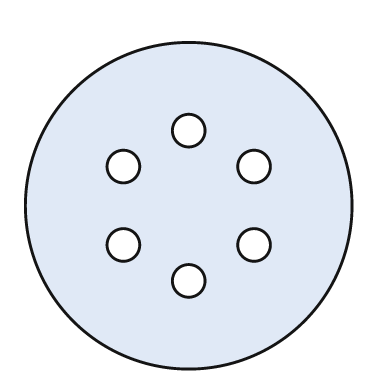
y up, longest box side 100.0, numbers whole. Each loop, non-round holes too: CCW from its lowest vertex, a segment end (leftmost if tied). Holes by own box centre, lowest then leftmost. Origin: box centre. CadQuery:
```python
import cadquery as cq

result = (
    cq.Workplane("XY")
    .moveTo(0.0, 0.0)
    .circle(50.0)
    .moveTo(0.0, -23.0)
    .circle(5.0)
    .moveTo(-20.0, -12.0)
    .circle(5.0)
    .moveTo(20.0, -12.0)
    .circle(5.0)
    .moveTo(-20.0, 12.0)
    .circle(5.0)
    .moveTo(20.0, 12.0)
    .circle(5.0)
    .moveTo(0.0, 23.0)
    .circle(5.0)
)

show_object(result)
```